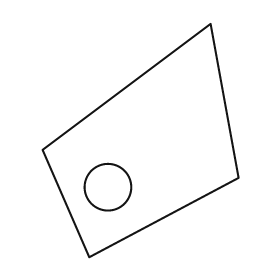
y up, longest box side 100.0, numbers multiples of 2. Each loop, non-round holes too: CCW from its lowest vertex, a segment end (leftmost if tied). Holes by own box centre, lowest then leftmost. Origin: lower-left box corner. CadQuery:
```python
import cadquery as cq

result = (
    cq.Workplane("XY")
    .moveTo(20.0, 0.0)
    .lineTo(84.0, 34.0)
    .lineTo(72.0, 100.0)
    .lineTo(0.0, 46.0)
    .close()
    .moveTo(28.0, 30.0)
    .circle(10.0)
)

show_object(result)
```